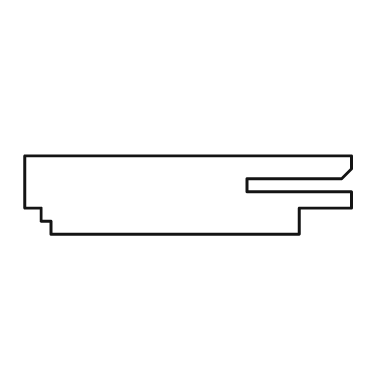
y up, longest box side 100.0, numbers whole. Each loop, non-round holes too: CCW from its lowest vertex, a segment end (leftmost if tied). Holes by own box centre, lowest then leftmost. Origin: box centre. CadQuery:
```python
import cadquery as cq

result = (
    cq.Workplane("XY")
    .moveTo(-42.0, -12.0)
    .lineTo(34.0, -12.0)
    .lineTo(34.0, -4.0)
    .lineTo(50.0, -4.0)
    .lineTo(50.0, 1.0)
    .lineTo(18.0, 1.0)
    .lineTo(18.0, 5.0)
    .lineTo(47.0, 5.0)
    .lineTo(50.0, 8.0)
    .lineTo(50.0, 12.0)
    .lineTo(-50.0, 12.0)
    .lineTo(-50.0, -4.0)
    .lineTo(-45.0, -4.0)
    .lineTo(-45.0, -8.0)
    .lineTo(-42.0, -8.0)
    .close()
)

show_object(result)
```